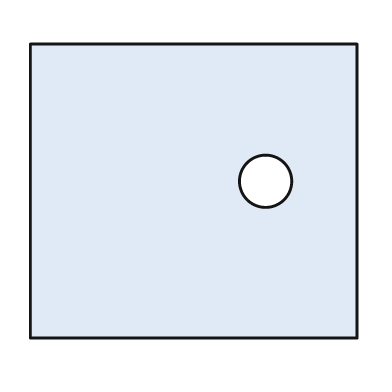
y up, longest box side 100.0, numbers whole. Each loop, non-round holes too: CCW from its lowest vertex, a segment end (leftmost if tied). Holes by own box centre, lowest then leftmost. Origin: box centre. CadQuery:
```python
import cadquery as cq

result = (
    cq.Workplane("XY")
    .moveTo(-50.0, -45.0)
    .lineTo(50.0, -45.0)
    .lineTo(50.0, 45.0)
    .lineTo(-50.0, 45.0)
    .close()
    .moveTo(22.0, 3.0)
    .circle(8.0)
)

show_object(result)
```